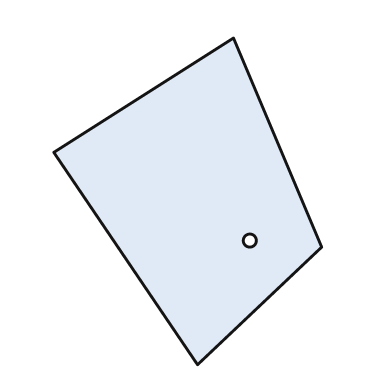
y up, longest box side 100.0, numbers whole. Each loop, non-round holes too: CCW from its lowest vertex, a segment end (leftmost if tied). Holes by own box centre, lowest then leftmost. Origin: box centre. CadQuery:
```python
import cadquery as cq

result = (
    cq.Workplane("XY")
    .moveTo(3.0, -50.0)
    .lineTo(41.0, -14.0)
    .lineTo(14.0, 50.0)
    .lineTo(-41.0, 15.0)
    .close()
    .moveTo(19.0, -12.0)
    .circle(2.0)
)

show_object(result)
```